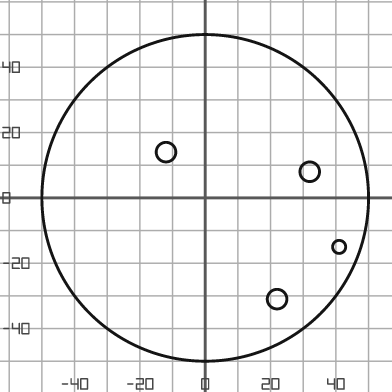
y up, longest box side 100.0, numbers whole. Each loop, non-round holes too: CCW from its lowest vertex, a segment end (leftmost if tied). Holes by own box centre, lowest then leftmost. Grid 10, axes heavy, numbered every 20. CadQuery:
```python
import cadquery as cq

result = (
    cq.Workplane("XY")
    .moveTo(0.0, 0.0)
    .circle(50.0)
    .moveTo(22.0, -31.0)
    .circle(3.0)
    .moveTo(41.0, -15.0)
    .circle(2.0)
    .moveTo(32.0, 8.0)
    .circle(3.0)
    .moveTo(-12.0, 14.0)
    .circle(3.0)
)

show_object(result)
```